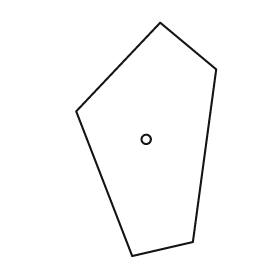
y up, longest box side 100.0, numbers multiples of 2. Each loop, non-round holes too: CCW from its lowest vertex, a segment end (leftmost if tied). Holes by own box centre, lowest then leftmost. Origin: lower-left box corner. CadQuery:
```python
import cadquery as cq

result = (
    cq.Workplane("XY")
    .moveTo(24.0, 0.0)
    .lineTo(50.0, 6.0)
    .lineTo(60.0, 80.0)
    .lineTo(36.0, 100.0)
    .lineTo(0.0, 62.0)
    .close()
    .moveTo(30.0, 50.0)
    .circle(2.0)
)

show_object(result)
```